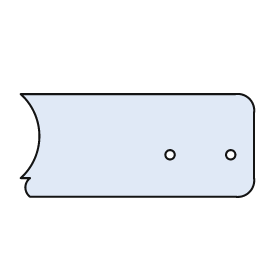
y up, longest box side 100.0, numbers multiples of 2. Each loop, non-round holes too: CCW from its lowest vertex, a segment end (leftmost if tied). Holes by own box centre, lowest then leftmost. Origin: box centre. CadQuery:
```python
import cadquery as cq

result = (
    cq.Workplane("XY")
    .moveTo(-46.0, -22.0)
    .lineTo(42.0, -22.0)
    .threePointArc((48.0, -20.0), (50.0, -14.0))
    .lineTo(50.0, 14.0)
    .threePointArc((48.0, 20.0), (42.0, 22.0))
    .lineTo(-50.0, 22.0)
    .threePointArc((-42.0, 4.0), (-50.0, -14.0))
    .lineTo(-46.0, -14.0)
    .threePointArc((-48.0, -18.0), (-46.0, -22.0))
    .close()
    .moveTo(14.0, -4.0)
    .circle(2.0)
    .moveTo(40.0, -4.0)
    .circle(2.0)
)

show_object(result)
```